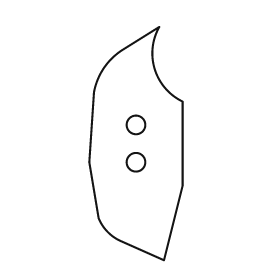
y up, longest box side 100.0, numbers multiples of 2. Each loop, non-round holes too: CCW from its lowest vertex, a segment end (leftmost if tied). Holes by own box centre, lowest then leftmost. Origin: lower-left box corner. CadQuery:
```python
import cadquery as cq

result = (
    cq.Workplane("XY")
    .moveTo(32.0, 0.0)
    .lineTo(40.0, 32.0)
    .lineTo(40.0, 68.0)
    .threePointArc((28.0, 82.0), (30.0, 100.0))
    .lineTo(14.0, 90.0)
    .threePointArc((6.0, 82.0), (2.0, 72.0))
    .lineTo(0.0, 42.0)
    .lineTo(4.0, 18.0)
    .threePointArc((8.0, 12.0), (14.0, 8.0))
    .close()
    .moveTo(20.0, 42.0)
    .circle(4.0)
    .moveTo(20.0, 58.0)
    .circle(4.0)
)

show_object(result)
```